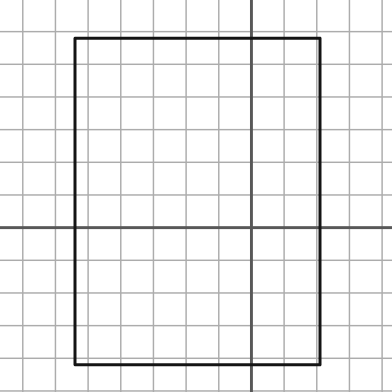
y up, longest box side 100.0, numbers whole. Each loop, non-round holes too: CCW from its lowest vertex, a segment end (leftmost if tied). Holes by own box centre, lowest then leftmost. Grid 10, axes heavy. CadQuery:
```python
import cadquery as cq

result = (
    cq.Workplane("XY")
    .moveTo(-54.0, -42.0)
    .lineTo(21.0, -42.0)
    .lineTo(21.0, 58.0)
    .lineTo(-54.0, 58.0)
    .close()
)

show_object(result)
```